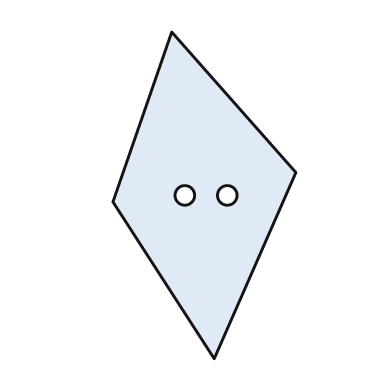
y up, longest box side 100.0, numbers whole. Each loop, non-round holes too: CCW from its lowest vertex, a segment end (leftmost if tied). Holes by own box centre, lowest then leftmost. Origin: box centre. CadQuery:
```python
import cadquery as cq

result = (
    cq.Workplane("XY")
    .moveTo(3.0, -50.0)
    .lineTo(28.0, 7.0)
    .lineTo(-10.0, 50.0)
    .lineTo(-28.0, -2.0)
    .close()
    .moveTo(-6.0, 0.0)
    .circle(3.0)
    .moveTo(7.0, 0.0)
    .circle(3.0)
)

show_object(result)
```